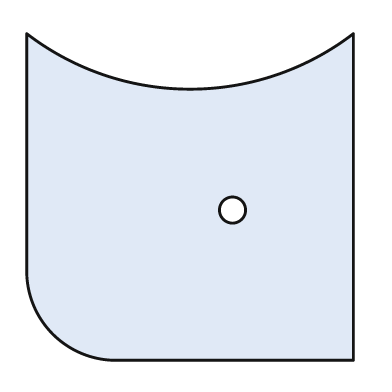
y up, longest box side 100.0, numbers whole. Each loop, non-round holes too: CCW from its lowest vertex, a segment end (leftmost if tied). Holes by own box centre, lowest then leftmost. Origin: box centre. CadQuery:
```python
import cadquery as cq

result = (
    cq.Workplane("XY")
    .moveTo(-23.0, -50.0)
    .lineTo(50.0, -50.0)
    .lineTo(50.0, 50.0)
    .threePointArc((0.0, 33.0), (-50.0, 50.0))
    .lineTo(-50.0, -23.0)
    .threePointArc((-42.0, -42.0), (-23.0, -50.0))
    .close()
    .moveTo(13.0, -4.0)
    .circle(4.0)
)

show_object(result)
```